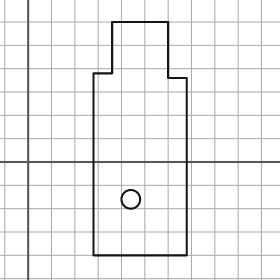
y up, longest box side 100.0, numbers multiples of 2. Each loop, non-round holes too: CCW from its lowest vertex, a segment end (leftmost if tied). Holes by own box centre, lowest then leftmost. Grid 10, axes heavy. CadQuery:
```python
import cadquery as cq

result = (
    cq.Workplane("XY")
    .moveTo(28.0, -40.0)
    .lineTo(68.0, -40.0)
    .lineTo(68.0, 36.0)
    .lineTo(60.0, 36.0)
    .lineTo(60.0, 60.0)
    .lineTo(36.0, 60.0)
    .lineTo(36.0, 38.0)
    .lineTo(28.0, 38.0)
    .close()
    .moveTo(44.0, -16.0)
    .circle(4.0)
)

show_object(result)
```